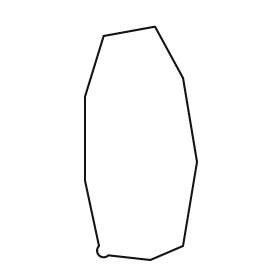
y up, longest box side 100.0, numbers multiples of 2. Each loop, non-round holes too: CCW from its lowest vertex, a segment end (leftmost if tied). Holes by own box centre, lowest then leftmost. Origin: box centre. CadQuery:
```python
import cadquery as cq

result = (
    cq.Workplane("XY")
    .moveTo(4.0, -50.0)
    .lineTo(18.0, -44.0)
    .lineTo(24.0, -8.0)
    .lineTo(18.0, 28.0)
    .lineTo(6.0, 50.0)
    .lineTo(-16.0, 46.0)
    .lineTo(-24.0, 20.0)
    .lineTo(-24.0, -16.0)
    .lineTo(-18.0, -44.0)
    .threePointArc((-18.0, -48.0), (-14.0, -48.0))
    .close()
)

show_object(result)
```